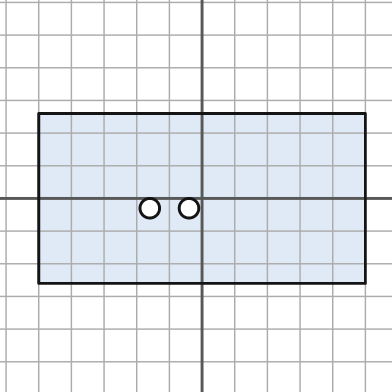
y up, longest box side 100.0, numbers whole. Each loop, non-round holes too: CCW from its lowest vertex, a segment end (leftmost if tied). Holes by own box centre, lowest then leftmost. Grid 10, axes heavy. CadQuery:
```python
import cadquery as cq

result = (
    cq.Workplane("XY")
    .moveTo(-50.0, -26.0)
    .lineTo(50.0, -26.0)
    .lineTo(50.0, 26.0)
    .lineTo(-50.0, 26.0)
    .close()
    .moveTo(-16.0, -3.0)
    .circle(3.0)
    .moveTo(-4.0, -3.0)
    .circle(3.0)
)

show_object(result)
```